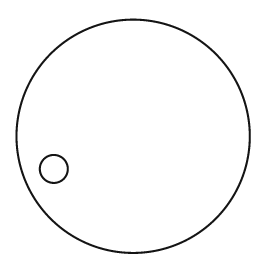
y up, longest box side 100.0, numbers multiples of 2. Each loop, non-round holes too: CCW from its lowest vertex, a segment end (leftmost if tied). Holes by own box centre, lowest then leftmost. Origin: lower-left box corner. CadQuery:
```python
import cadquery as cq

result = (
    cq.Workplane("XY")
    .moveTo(50.0, 50.0)
    .circle(50.0)
    .moveTo(16.0, 36.0)
    .circle(6.0)
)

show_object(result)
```